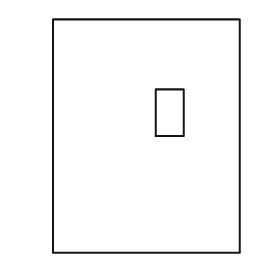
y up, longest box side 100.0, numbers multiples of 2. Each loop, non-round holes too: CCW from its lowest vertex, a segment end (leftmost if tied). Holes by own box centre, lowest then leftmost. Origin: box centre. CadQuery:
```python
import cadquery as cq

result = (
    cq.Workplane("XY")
    .moveTo(-40.0, -50.0)
    .lineTo(40.0, -50.0)
    .lineTo(40.0, 50.0)
    .lineTo(-40.0, 50.0)
    .close()
    .moveTo(4.0, 0.0)
    .lineTo(16.0, 0.0)
    .lineTo(16.0, 20.0)
    .lineTo(4.0, 20.0)
    .close()
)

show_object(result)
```